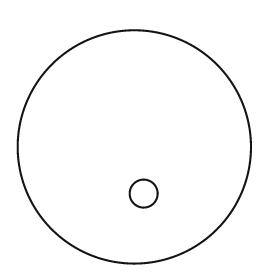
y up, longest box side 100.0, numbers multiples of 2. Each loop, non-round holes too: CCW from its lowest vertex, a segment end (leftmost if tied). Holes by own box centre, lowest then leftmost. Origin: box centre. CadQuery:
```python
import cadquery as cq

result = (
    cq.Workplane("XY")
    .moveTo(0.0, 0.0)
    .circle(50.0)
    .moveTo(4.0, -20.0)
    .circle(6.0)
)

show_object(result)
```